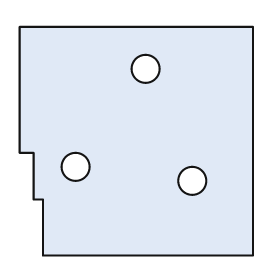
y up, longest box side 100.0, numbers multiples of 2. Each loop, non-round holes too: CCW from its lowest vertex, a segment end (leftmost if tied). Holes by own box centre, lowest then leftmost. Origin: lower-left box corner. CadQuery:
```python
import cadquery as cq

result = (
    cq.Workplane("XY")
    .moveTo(10.0, 0.0)
    .lineTo(100.0, 0.0)
    .lineTo(100.0, 98.0)
    .lineTo(0.0, 98.0)
    .lineTo(0.0, 44.0)
    .lineTo(6.0, 44.0)
    .lineTo(6.0, 24.0)
    .lineTo(10.0, 24.0)
    .close()
    .moveTo(74.0, 32.0)
    .circle(6.0)
    .moveTo(24.0, 38.0)
    .circle(6.0)
    .moveTo(54.0, 80.0)
    .circle(6.0)
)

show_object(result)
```